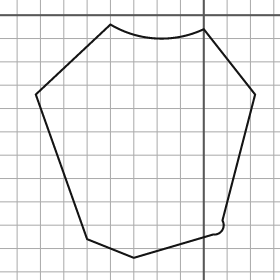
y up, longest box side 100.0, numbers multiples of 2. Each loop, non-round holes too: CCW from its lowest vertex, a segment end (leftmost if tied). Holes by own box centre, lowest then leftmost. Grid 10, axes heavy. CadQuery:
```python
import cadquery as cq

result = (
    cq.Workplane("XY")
    .moveTo(-30.0, -104.0)
    .lineTo(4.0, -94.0)
    .threePointArc((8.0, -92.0), (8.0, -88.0))
    .lineTo(22.0, -34.0)
    .lineTo(0.0, -6.0)
    .threePointArc((-20.0, -10.0), (-40.0, -4.0))
    .lineTo(-72.0, -34.0)
    .lineTo(-50.0, -96.0)
    .close()
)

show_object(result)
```